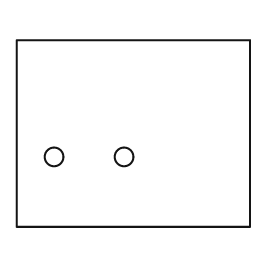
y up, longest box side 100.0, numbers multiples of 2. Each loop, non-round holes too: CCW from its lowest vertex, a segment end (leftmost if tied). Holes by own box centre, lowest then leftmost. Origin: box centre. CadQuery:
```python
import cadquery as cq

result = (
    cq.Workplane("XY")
    .moveTo(-50.0, -40.0)
    .lineTo(50.0, -40.0)
    .lineTo(50.0, 40.0)
    .lineTo(-50.0, 40.0)
    .close()
    .moveTo(-34.0, -10.0)
    .circle(4.0)
    .moveTo(-4.0, -10.0)
    .circle(4.0)
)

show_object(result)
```